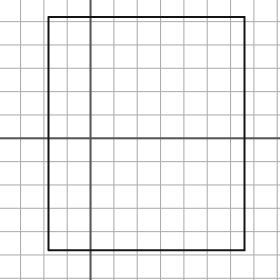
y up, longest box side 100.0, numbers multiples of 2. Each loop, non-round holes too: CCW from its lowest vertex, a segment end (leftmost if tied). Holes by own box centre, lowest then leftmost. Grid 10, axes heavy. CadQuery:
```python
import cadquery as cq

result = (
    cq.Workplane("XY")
    .moveTo(-18.0, -48.0)
    .lineTo(66.0, -48.0)
    .lineTo(66.0, 52.0)
    .lineTo(-18.0, 52.0)
    .close()
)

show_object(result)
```